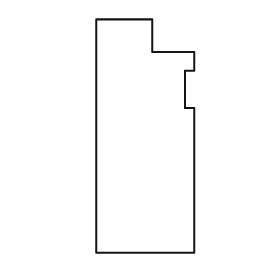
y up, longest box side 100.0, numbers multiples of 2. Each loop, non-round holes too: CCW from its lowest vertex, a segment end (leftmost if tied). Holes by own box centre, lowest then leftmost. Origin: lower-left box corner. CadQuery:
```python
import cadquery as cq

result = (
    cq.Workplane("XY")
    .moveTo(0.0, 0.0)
    .lineTo(42.0, 0.0)
    .lineTo(42.0, 62.0)
    .lineTo(38.0, 62.0)
    .lineTo(38.0, 78.0)
    .lineTo(42.0, 78.0)
    .lineTo(42.0, 86.0)
    .lineTo(24.0, 86.0)
    .lineTo(24.0, 100.0)
    .lineTo(0.0, 100.0)
    .close()
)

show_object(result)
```